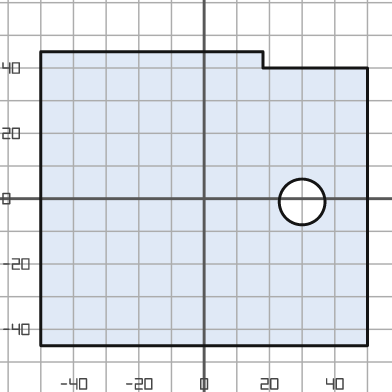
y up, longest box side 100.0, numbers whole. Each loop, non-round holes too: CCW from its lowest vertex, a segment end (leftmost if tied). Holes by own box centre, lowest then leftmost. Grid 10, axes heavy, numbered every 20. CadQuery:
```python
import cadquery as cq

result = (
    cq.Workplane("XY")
    .moveTo(-50.0, -45.0)
    .lineTo(50.0, -45.0)
    .lineTo(50.0, 40.0)
    .lineTo(18.0, 40.0)
    .lineTo(18.0, 45.0)
    .lineTo(-50.0, 45.0)
    .close()
    .moveTo(30.0, -1.0)
    .circle(7.0)
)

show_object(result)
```